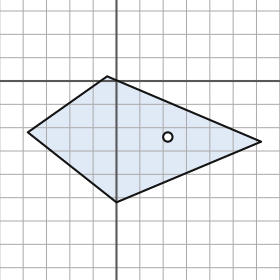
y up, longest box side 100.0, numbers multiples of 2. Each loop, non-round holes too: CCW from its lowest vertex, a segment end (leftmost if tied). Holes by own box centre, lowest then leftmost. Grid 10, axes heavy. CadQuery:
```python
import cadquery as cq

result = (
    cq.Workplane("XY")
    .moveTo(0.0, -52.0)
    .lineTo(62.0, -26.0)
    .lineTo(-4.0, 2.0)
    .lineTo(-38.0, -22.0)
    .close()
    .moveTo(22.0, -24.0)
    .circle(2.0)
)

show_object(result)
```